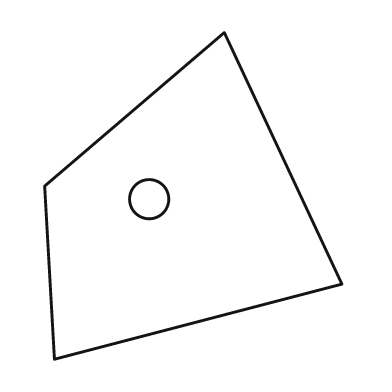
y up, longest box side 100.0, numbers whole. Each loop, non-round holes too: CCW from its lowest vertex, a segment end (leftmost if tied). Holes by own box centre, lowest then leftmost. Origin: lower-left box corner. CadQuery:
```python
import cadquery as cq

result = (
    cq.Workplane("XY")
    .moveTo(3.0, 0.0)
    .lineTo(91.0, 23.0)
    .lineTo(55.0, 100.0)
    .lineTo(0.0, 53.0)
    .close()
    .moveTo(32.0, 49.0)
    .circle(6.0)
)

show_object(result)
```